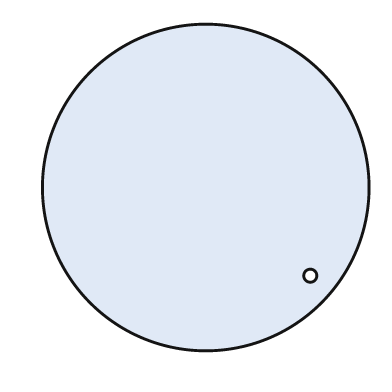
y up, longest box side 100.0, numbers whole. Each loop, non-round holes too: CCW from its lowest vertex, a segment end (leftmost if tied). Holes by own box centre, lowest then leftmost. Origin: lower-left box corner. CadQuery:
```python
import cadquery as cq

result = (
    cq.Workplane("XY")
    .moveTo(50.0, 50.0)
    .circle(50.0)
    .moveTo(82.0, 23.0)
    .circle(2.0)
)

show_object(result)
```